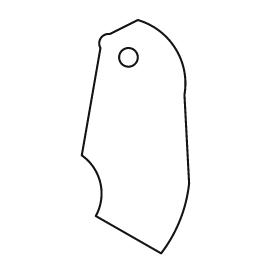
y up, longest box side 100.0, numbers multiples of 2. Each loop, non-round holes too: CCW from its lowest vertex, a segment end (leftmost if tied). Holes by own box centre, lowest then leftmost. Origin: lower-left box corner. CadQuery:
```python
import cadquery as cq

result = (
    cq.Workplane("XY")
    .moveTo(34.0, 0.0)
    .threePointArc((42.0, 14.0), (46.0, 30.0))
    .lineTo(44.0, 68.0)
    .threePointArc((40.0, 88.0), (24.0, 100.0))
    .lineTo(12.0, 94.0)
    .threePointArc((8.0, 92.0), (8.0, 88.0))
    .lineTo(0.0, 42.0)
    .threePointArc((8.0, 30.0), (6.0, 16.0))
    .close()
    .moveTo(20.0, 84.0)
    .circle(4.0)
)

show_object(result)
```